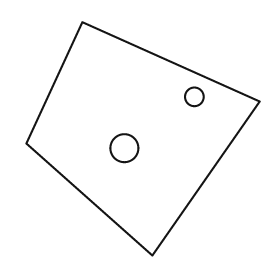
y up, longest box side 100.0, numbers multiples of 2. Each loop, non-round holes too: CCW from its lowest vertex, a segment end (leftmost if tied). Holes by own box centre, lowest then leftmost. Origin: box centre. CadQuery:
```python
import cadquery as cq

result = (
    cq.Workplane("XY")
    .moveTo(4.0, -50.0)
    .lineTo(50.0, 16.0)
    .lineTo(-26.0, 50.0)
    .lineTo(-50.0, -2.0)
    .close()
    .moveTo(-8.0, -4.0)
    .circle(6.0)
    .moveTo(22.0, 18.0)
    .circle(4.0)
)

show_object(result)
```